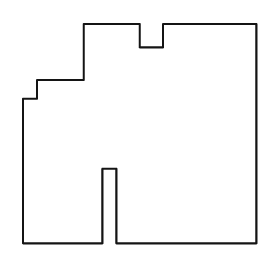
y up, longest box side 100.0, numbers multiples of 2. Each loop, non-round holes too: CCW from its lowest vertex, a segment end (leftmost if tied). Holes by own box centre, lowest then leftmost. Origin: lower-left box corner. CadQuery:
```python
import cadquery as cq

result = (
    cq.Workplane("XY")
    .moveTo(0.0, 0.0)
    .lineTo(34.0, 0.0)
    .lineTo(34.0, 32.0)
    .lineTo(40.0, 32.0)
    .lineTo(40.0, 0.0)
    .lineTo(100.0, 0.0)
    .lineTo(100.0, 94.0)
    .lineTo(60.0, 94.0)
    .lineTo(60.0, 84.0)
    .lineTo(50.0, 84.0)
    .lineTo(50.0, 94.0)
    .lineTo(26.0, 94.0)
    .lineTo(26.0, 70.0)
    .lineTo(6.0, 70.0)
    .lineTo(6.0, 62.0)
    .lineTo(0.0, 62.0)
    .close()
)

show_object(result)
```